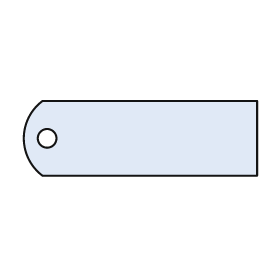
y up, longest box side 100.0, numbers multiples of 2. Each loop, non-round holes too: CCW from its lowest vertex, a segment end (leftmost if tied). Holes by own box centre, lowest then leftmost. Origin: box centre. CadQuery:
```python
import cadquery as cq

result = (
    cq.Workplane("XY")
    .moveTo(-42.0, -16.0)
    .lineTo(50.0, -16.0)
    .lineTo(50.0, 16.0)
    .lineTo(-42.0, 16.0)
    .threePointArc((-50.0, 0.0), (-42.0, -16.0))
    .close()
    .moveTo(-40.0, 0.0)
    .circle(4.0)
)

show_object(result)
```